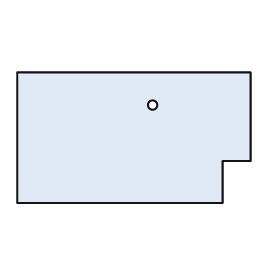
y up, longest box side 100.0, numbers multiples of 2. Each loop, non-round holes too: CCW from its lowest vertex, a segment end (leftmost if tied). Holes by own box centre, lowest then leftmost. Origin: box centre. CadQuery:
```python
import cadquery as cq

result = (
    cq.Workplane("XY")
    .moveTo(-50.0, -28.0)
    .lineTo(38.0, -28.0)
    .lineTo(38.0, -10.0)
    .lineTo(50.0, -10.0)
    .lineTo(50.0, 28.0)
    .lineTo(-50.0, 28.0)
    .close()
    .moveTo(8.0, 14.0)
    .circle(2.0)
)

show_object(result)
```